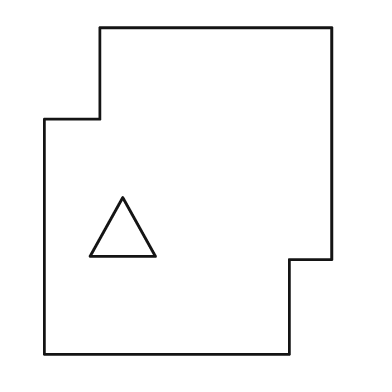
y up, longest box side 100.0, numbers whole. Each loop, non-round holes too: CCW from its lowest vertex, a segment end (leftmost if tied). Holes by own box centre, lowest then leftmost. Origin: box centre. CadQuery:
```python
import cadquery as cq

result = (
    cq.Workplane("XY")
    .moveTo(-44.0, -50.0)
    .lineTo(31.0, -50.0)
    .lineTo(31.0, -21.0)
    .lineTo(44.0, -21.0)
    .lineTo(44.0, 50.0)
    .lineTo(-27.0, 50.0)
    .lineTo(-27.0, 22.0)
    .lineTo(-44.0, 22.0)
    .close()
    .moveTo(-30.0, -20.0)
    .lineTo(-10.0, -20.0)
    .lineTo(-20.0, -2.0)
    .close()
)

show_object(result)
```